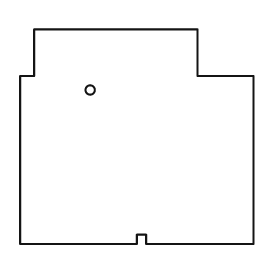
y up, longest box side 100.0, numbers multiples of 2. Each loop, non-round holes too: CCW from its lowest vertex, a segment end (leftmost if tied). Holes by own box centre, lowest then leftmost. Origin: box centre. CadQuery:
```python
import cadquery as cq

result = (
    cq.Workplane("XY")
    .moveTo(-50.0, -46.0)
    .lineTo(0.0, -46.0)
    .lineTo(0.0, -42.0)
    .lineTo(4.0, -42.0)
    .lineTo(4.0, -46.0)
    .lineTo(50.0, -46.0)
    .lineTo(50.0, 26.0)
    .lineTo(26.0, 26.0)
    .lineTo(26.0, 46.0)
    .lineTo(-44.0, 46.0)
    .lineTo(-44.0, 26.0)
    .lineTo(-50.0, 26.0)
    .close()
    .moveTo(-20.0, 20.0)
    .circle(2.0)
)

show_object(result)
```